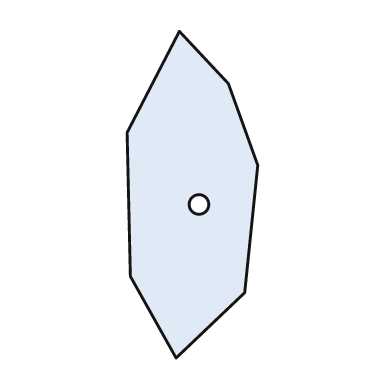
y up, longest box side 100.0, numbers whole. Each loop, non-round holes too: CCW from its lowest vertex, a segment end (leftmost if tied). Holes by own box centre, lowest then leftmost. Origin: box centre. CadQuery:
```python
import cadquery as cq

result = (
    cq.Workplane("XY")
    .moveTo(-5.0, -50.0)
    .lineTo(16.0, -30.0)
    .lineTo(20.0, 9.0)
    .lineTo(11.0, 34.0)
    .lineTo(-4.0, 50.0)
    .lineTo(-20.0, 19.0)
    .lineTo(-19.0, -25.0)
    .close()
    .moveTo(2.0, -3.0)
    .circle(3.0)
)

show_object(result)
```